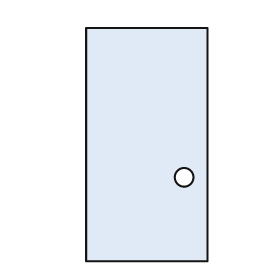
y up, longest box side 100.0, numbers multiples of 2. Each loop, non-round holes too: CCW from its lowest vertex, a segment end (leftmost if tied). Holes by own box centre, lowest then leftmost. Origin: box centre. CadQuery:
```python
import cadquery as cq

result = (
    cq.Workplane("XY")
    .moveTo(-26.0, -50.0)
    .lineTo(26.0, -50.0)
    .lineTo(26.0, 50.0)
    .lineTo(-26.0, 50.0)
    .close()
    .moveTo(16.0, -14.0)
    .circle(4.0)
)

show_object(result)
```